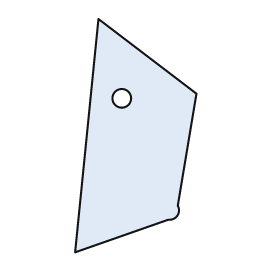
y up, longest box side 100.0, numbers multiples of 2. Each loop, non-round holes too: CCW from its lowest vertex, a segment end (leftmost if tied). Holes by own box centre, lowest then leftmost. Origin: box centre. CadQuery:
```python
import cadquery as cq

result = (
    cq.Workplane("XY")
    .moveTo(-26.0, -50.0)
    .lineTo(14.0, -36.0)
    .threePointArc((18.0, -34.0), (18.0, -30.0))
    .lineTo(26.0, 18.0)
    .lineTo(-16.0, 50.0)
    .close()
    .moveTo(-6.0, 16.0)
    .circle(4.0)
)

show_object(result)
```